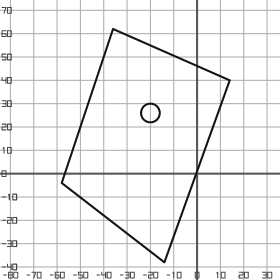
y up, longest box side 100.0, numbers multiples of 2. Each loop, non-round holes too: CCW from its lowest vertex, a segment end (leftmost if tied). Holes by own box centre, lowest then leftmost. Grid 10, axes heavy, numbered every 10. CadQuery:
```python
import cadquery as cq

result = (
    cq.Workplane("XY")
    .moveTo(-14.0, -38.0)
    .lineTo(14.0, 40.0)
    .lineTo(-36.0, 62.0)
    .lineTo(-58.0, -4.0)
    .close()
    .moveTo(-20.0, 26.0)
    .circle(4.0)
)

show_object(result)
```